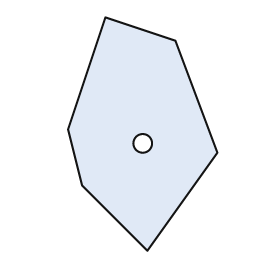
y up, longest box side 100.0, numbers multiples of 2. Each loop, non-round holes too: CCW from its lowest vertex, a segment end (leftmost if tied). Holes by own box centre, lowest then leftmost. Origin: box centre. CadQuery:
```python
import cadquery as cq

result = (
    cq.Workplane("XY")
    .moveTo(2.0, -50.0)
    .lineTo(32.0, -8.0)
    .lineTo(14.0, 40.0)
    .lineTo(-16.0, 50.0)
    .lineTo(-32.0, 2.0)
    .lineTo(-26.0, -22.0)
    .close()
    .moveTo(0.0, -4.0)
    .circle(4.0)
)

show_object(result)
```